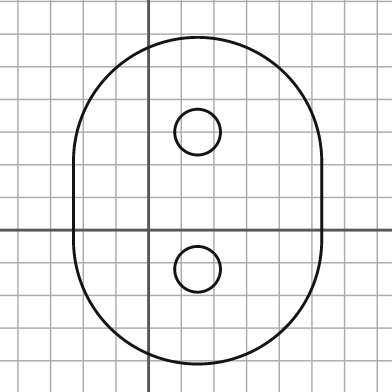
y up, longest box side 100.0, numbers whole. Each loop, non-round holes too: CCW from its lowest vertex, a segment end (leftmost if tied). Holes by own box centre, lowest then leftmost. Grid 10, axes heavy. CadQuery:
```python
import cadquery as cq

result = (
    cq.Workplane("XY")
    .moveTo(-23.0, -3.0)
    .threePointArc((15.0, -41.0), (53.0, -3.0))
    .lineTo(53.0, 21.0)
    .threePointArc((15.0, 59.0), (-23.0, 21.0))
    .close()
    .moveTo(15.0, -12.0)
    .circle(7.0)
    .moveTo(15.0, 30.0)
    .circle(7.0)
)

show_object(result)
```